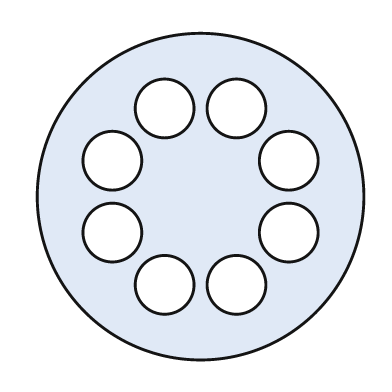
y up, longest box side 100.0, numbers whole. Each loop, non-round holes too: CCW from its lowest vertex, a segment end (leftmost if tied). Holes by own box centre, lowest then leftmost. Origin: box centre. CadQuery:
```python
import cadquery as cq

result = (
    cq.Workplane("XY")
    .moveTo(0.0, 0.0)
    .circle(50.0)
    .moveTo(-11.0, -27.0)
    .circle(9.0)
    .moveTo(11.0, -27.0)
    .circle(9.0)
    .moveTo(-27.0, -11.0)
    .circle(9.0)
    .moveTo(27.0, -11.0)
    .circle(9.0)
    .moveTo(-27.0, 11.0)
    .circle(9.0)
    .moveTo(27.0, 11.0)
    .circle(9.0)
    .moveTo(-11.0, 27.0)
    .circle(9.0)
    .moveTo(11.0, 27.0)
    .circle(9.0)
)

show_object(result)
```